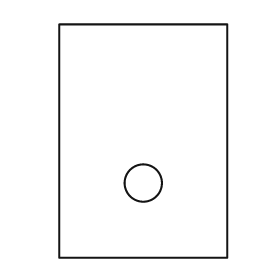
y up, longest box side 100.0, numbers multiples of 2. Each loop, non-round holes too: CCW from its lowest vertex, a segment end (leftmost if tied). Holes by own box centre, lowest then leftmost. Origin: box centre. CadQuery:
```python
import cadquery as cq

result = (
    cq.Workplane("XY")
    .moveTo(-36.0, -50.0)
    .lineTo(36.0, -50.0)
    .lineTo(36.0, 50.0)
    .lineTo(-36.0, 50.0)
    .close()
    .moveTo(0.0, -18.0)
    .circle(8.0)
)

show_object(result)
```